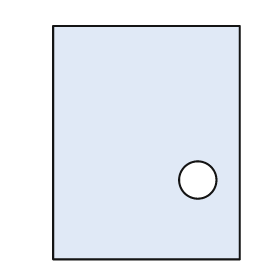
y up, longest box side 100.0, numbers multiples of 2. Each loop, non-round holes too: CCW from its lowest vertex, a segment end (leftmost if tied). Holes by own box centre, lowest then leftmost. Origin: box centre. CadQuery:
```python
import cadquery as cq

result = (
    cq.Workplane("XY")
    .moveTo(-40.0, -50.0)
    .lineTo(40.0, -50.0)
    .lineTo(40.0, 50.0)
    .lineTo(-40.0, 50.0)
    .close()
    .moveTo(22.0, -16.0)
    .circle(8.0)
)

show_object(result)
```